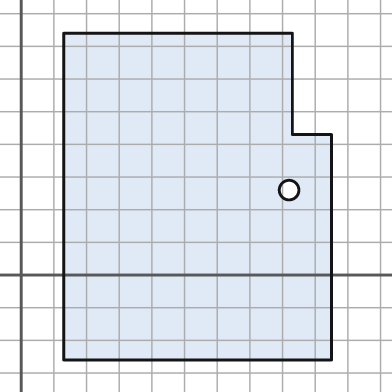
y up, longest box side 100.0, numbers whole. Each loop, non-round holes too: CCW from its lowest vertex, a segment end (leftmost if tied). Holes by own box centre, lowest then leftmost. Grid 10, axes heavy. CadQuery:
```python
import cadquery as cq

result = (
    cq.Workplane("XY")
    .moveTo(13.0, -26.0)
    .lineTo(95.0, -26.0)
    .lineTo(95.0, 43.0)
    .lineTo(83.0, 43.0)
    .lineTo(83.0, 74.0)
    .lineTo(13.0, 74.0)
    .close()
    .moveTo(82.0, 26.0)
    .circle(3.0)
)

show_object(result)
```